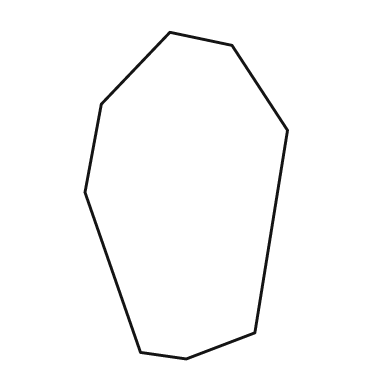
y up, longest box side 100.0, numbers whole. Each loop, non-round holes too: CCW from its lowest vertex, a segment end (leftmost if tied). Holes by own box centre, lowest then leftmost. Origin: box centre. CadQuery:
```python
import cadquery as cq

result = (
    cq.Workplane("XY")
    .moveTo(0.0, -50.0)
    .lineTo(21.0, -42.0)
    .lineTo(31.0, 20.0)
    .lineTo(14.0, 46.0)
    .lineTo(-5.0, 50.0)
    .lineTo(-26.0, 28.0)
    .lineTo(-31.0, 1.0)
    .lineTo(-14.0, -48.0)
    .close()
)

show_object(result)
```